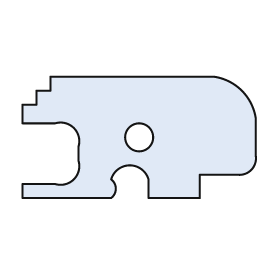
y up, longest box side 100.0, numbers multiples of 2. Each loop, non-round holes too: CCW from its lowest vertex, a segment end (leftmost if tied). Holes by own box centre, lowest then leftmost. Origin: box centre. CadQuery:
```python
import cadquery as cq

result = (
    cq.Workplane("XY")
    .moveTo(-50.0, -26.0)
    .lineTo(-12.0, -26.0)
    .threePointArc((-10.0, -22.0), (-12.0, -18.0))
    .threePointArc((-4.0, -12.0), (4.0, -18.0))
    .lineTo(4.0, -26.0)
    .lineTo(26.0, -26.0)
    .lineTo(26.0, -16.0)
    .lineTo(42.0, -16.0)
    .threePointArc((48.0, -14.0), (50.0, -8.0))
    .lineTo(50.0, 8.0)
    .threePointArc((44.0, 20.0), (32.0, 26.0))
    .lineTo(-38.0, 26.0)
    .lineTo(-38.0, 20.0)
    .lineTo(-44.0, 20.0)
    .lineTo(-44.0, 14.0)
    .lineTo(-50.0, 14.0)
    .lineTo(-50.0, 6.0)
    .lineTo(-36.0, 6.0)
    .threePointArc((-28.0, 4.0), (-26.0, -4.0))
    .lineTo(-26.0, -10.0)
    .threePointArc((-28.0, -18.0), (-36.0, -20.0))
    .lineTo(-50.0, -20.0)
    .close()
    .moveTo(0.0, 0.0)
    .circle(6.0)
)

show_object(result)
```